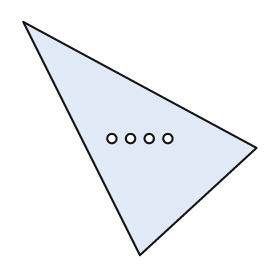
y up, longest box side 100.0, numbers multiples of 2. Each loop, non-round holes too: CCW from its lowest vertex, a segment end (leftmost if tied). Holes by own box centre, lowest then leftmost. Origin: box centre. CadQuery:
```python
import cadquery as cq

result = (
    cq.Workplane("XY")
    .moveTo(0.0, -50.0)
    .lineTo(50.0, -4.0)
    .lineTo(-50.0, 50.0)
    .close()
    .moveTo(-12.0, 0.0)
    .circle(2.0)
    .moveTo(-4.0, 0.0)
    .circle(2.0)
    .moveTo(4.0, 0.0)
    .circle(2.0)
    .moveTo(12.0, 0.0)
    .circle(2.0)
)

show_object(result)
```